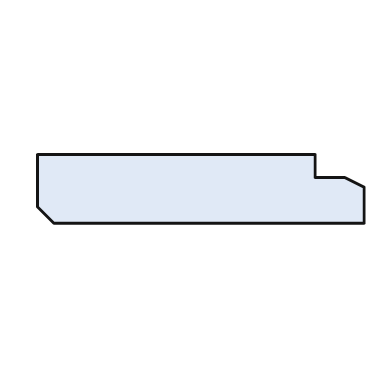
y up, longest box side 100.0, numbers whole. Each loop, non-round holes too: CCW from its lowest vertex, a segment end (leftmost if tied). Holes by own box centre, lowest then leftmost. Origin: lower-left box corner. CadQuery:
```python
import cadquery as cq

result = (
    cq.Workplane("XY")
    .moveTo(5.0, 0.0)
    .lineTo(100.0, 0.0)
    .lineTo(100.0, 11.0)
    .lineTo(94.0, 14.0)
    .lineTo(85.0, 14.0)
    .lineTo(85.0, 21.0)
    .lineTo(0.0, 21.0)
    .lineTo(0.0, 5.0)
    .close()
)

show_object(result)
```